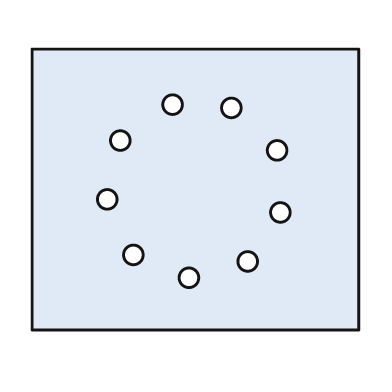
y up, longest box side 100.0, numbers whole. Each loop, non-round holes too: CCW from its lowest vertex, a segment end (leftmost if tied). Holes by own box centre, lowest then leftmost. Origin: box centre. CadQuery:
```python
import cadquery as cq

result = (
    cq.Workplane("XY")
    .moveTo(-50.0, -43.0)
    .lineTo(50.0, -43.0)
    .lineTo(50.0, 43.0)
    .lineTo(-50.0, 43.0)
    .close()
    .moveTo(-2.0, -27.0)
    .circle(3.0)
    .moveTo(16.0, -22.0)
    .circle(3.0)
    .moveTo(-19.0, -20.0)
    .circle(3.0)
    .moveTo(26.0, -7.0)
    .circle(3.0)
    .moveTo(-27.0, -3.0)
    .circle(3.0)
    .moveTo(25.0, 12.0)
    .circle(3.0)
    .moveTo(-23.0, 15.0)
    .circle(3.0)
    .moveTo(11.0, 25.0)
    .circle(3.0)
    .moveTo(-7.0, 26.0)
    .circle(3.0)
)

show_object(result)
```